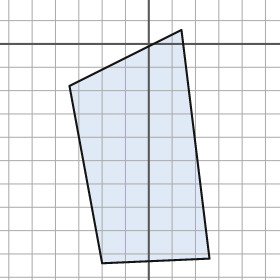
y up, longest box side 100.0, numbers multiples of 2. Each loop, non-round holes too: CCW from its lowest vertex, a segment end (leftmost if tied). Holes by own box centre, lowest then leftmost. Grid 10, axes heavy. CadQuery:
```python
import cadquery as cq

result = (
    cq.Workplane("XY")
    .moveTo(-20.0, -94.0)
    .lineTo(26.0, -92.0)
    .lineTo(14.0, 6.0)
    .lineTo(-34.0, -18.0)
    .close()
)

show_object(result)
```